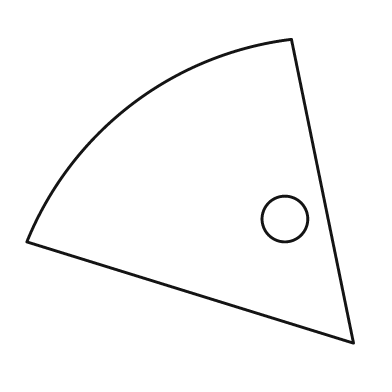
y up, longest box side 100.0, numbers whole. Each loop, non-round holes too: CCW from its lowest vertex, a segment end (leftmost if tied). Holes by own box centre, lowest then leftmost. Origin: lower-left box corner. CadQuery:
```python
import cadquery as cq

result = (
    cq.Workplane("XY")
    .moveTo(100.0, 0.0)
    .lineTo(81.0, 93.0)
    .threePointArc((32.0, 73.0), (0.0, 31.0))
    .close()
    .moveTo(79.0, 38.0)
    .circle(7.0)
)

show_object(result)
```